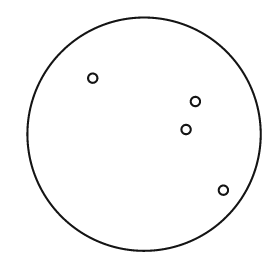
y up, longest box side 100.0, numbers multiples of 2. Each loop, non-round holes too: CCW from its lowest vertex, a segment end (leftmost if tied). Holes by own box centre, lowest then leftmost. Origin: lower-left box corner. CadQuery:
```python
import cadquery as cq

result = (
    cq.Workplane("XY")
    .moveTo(50.0, 50.0)
    .circle(50.0)
    .moveTo(84.0, 26.0)
    .circle(2.0)
    .moveTo(68.0, 52.0)
    .circle(2.0)
    .moveTo(72.0, 64.0)
    .circle(2.0)
    .moveTo(28.0, 74.0)
    .circle(2.0)
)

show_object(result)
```